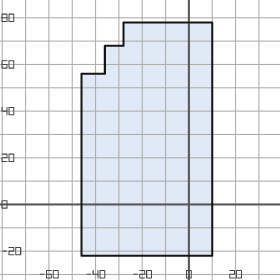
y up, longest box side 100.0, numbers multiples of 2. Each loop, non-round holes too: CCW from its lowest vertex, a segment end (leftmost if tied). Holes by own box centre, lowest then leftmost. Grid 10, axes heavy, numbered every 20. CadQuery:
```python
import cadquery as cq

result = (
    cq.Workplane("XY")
    .moveTo(-46.0, -22.0)
    .lineTo(10.0, -22.0)
    .lineTo(10.0, 78.0)
    .lineTo(-28.0, 78.0)
    .lineTo(-28.0, 68.0)
    .lineTo(-36.0, 68.0)
    .lineTo(-36.0, 56.0)
    .lineTo(-46.0, 56.0)
    .close()
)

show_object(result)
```